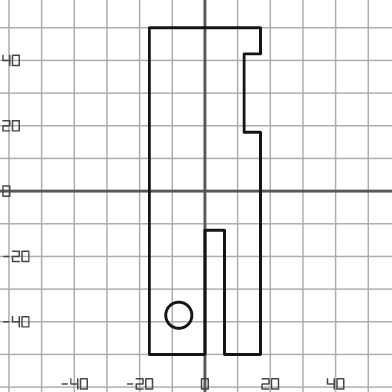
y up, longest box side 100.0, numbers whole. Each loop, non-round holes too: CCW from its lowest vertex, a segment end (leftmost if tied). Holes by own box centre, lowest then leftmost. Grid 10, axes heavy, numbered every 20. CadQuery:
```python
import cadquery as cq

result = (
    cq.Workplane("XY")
    .moveTo(-17.0, -50.0)
    .lineTo(0.0, -50.0)
    .lineTo(0.0, -12.0)
    .lineTo(6.0, -12.0)
    .lineTo(6.0, -50.0)
    .lineTo(17.0, -50.0)
    .lineTo(17.0, 18.0)
    .lineTo(12.0, 18.0)
    .lineTo(12.0, 42.0)
    .lineTo(17.0, 42.0)
    .lineTo(17.0, 50.0)
    .lineTo(-17.0, 50.0)
    .close()
    .moveTo(-8.0, -38.0)
    .circle(4.0)
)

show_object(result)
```